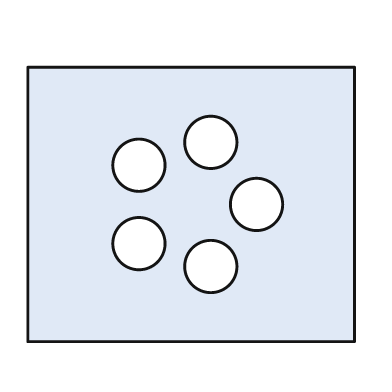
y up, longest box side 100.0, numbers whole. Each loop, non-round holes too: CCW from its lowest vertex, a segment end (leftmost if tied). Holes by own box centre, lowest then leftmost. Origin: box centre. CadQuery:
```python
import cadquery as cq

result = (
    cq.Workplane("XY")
    .moveTo(-50.0, -42.0)
    .lineTo(50.0, -42.0)
    .lineTo(50.0, 42.0)
    .lineTo(-50.0, 42.0)
    .close()
    .moveTo(6.0, -19.0)
    .circle(8.0)
    .moveTo(-16.0, -12.0)
    .circle(8.0)
    .moveTo(20.0, 0.0)
    .circle(8.0)
    .moveTo(-16.0, 12.0)
    .circle(8.0)
    .moveTo(6.0, 19.0)
    .circle(8.0)
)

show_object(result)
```